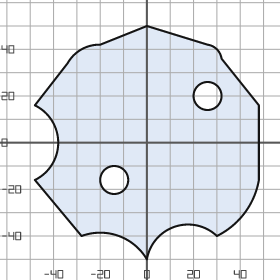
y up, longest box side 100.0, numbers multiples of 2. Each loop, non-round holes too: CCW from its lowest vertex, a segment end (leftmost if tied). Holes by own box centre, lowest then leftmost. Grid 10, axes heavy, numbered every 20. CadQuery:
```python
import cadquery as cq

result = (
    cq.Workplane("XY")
    .moveTo(0.0, -50.0)
    .threePointArc((12.0, -36.0), (30.0, -40.0))
    .threePointArc((42.0, -30.0), (48.0, -16.0))
    .lineTo(48.0, 16.0)
    .lineTo(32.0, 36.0)
    .threePointArc((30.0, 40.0), (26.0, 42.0))
    .lineTo(0.0, 50.0)
    .lineTo(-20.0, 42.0)
    .threePointArc((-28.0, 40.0), (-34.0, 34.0))
    .lineTo(-48.0, 16.0)
    .threePointArc((-38.0, 0.0), (-48.0, -16.0))
    .lineTo(-28.0, -40.0)
    .threePointArc((-12.0, -40.0), (0.0, -50.0))
    .close()
    .moveTo(-14.0, -16.0)
    .circle(6.0)
    .moveTo(26.0, 20.0)
    .circle(6.0)
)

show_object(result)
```